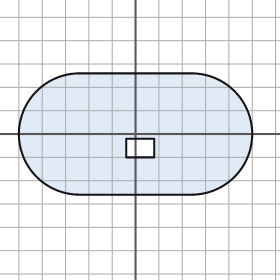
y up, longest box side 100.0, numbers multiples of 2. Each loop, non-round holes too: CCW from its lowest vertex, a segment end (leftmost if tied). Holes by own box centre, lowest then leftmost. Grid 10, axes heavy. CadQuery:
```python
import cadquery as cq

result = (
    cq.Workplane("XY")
    .moveTo(-24.0, -26.0)
    .lineTo(24.0, -26.0)
    .threePointArc((50.0, 0.0), (24.0, 26.0))
    .lineTo(-24.0, 26.0)
    .threePointArc((-50.0, 0.0), (-24.0, -26.0))
    .close()
    .moveTo(-4.0, -10.0)
    .lineTo(8.0, -10.0)
    .lineTo(8.0, -2.0)
    .lineTo(-4.0, -2.0)
    .close()
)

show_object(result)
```